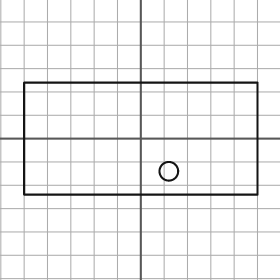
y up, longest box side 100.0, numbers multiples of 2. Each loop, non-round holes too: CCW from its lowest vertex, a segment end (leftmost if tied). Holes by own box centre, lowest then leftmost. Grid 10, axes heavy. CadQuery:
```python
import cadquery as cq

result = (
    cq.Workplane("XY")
    .moveTo(-50.0, -24.0)
    .lineTo(50.0, -24.0)
    .lineTo(50.0, 24.0)
    .lineTo(-50.0, 24.0)
    .close()
    .moveTo(12.0, -14.0)
    .circle(4.0)
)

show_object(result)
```